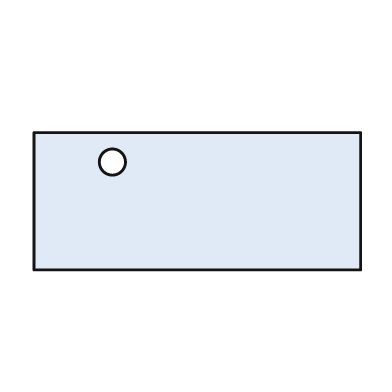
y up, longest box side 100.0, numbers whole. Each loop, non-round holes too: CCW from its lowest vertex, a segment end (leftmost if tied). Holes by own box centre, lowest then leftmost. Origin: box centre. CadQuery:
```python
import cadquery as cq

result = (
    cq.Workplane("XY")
    .moveTo(-50.0, -21.0)
    .lineTo(50.0, -21.0)
    .lineTo(50.0, 21.0)
    .lineTo(-50.0, 21.0)
    .close()
    .moveTo(-26.0, 12.0)
    .circle(4.0)
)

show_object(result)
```